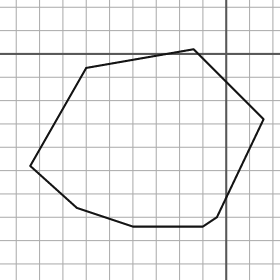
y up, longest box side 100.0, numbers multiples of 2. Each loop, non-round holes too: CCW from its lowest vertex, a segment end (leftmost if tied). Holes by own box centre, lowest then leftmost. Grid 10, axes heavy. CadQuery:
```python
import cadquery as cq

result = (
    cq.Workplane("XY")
    .moveTo(-40.0, -74.0)
    .lineTo(-10.0, -74.0)
    .lineTo(-4.0, -70.0)
    .lineTo(16.0, -28.0)
    .lineTo(-14.0, 2.0)
    .lineTo(-60.0, -6.0)
    .lineTo(-84.0, -48.0)
    .lineTo(-64.0, -66.0)
    .close()
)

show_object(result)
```